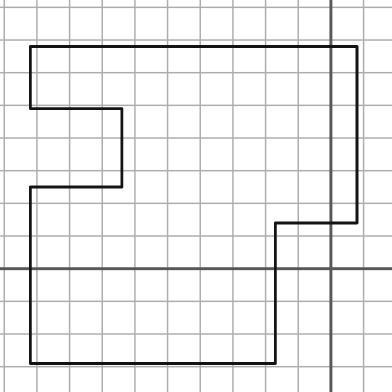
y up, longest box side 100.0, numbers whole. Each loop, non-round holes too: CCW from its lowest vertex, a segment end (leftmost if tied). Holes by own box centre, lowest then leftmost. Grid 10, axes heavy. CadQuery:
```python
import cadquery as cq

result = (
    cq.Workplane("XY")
    .moveTo(-92.0, -29.0)
    .lineTo(-17.0, -29.0)
    .lineTo(-17.0, 14.0)
    .lineTo(8.0, 14.0)
    .lineTo(8.0, 68.0)
    .lineTo(-92.0, 68.0)
    .lineTo(-92.0, 49.0)
    .lineTo(-64.0, 49.0)
    .lineTo(-64.0, 25.0)
    .lineTo(-92.0, 25.0)
    .close()
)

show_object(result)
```